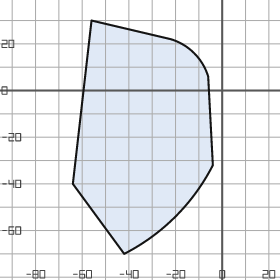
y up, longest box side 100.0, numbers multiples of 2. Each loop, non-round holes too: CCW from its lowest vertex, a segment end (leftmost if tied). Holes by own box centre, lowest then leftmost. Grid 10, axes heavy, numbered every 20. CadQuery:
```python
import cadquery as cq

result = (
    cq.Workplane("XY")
    .moveTo(-42.0, -70.0)
    .threePointArc((-20.0, -54.0), (-4.0, -32.0))
    .lineTo(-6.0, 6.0)
    .threePointArc((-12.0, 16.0), (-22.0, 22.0))
    .lineTo(-56.0, 30.0)
    .lineTo(-64.0, -40.0)
    .close()
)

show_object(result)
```